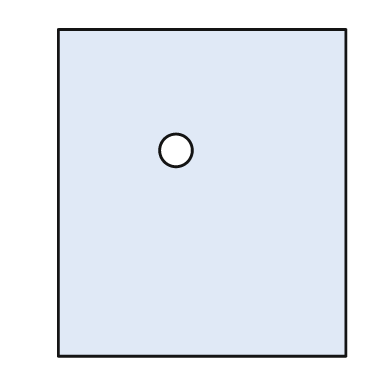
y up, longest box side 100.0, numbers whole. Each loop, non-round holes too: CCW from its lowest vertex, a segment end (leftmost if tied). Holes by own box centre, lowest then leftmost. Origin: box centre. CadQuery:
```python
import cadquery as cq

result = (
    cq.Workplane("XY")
    .moveTo(-44.0, -50.0)
    .lineTo(44.0, -50.0)
    .lineTo(44.0, 50.0)
    .lineTo(-44.0, 50.0)
    .close()
    .moveTo(-8.0, 13.0)
    .circle(5.0)
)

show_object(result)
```